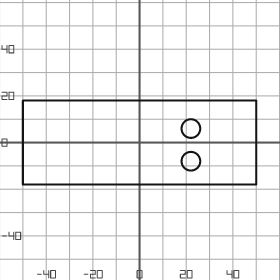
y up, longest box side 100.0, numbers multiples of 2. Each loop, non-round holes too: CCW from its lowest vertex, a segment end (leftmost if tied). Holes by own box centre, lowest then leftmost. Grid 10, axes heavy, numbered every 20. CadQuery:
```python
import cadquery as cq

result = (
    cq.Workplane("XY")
    .moveTo(-50.0, -18.0)
    .lineTo(50.0, -18.0)
    .lineTo(50.0, 18.0)
    .lineTo(-50.0, 18.0)
    .close()
    .moveTo(22.0, -8.0)
    .circle(4.0)
    .moveTo(22.0, 6.0)
    .circle(4.0)
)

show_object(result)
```